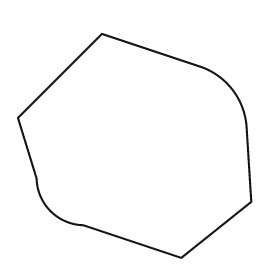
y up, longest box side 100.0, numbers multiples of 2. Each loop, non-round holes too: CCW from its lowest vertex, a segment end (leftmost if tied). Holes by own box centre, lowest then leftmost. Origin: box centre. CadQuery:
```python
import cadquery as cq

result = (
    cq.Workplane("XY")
    .moveTo(20.0, -48.0)
    .lineTo(50.0, -24.0)
    .lineTo(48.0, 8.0)
    .threePointArc((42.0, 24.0), (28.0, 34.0))
    .lineTo(-14.0, 48.0)
    .lineTo(-50.0, 12.0)
    .lineTo(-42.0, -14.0)
    .threePointArc((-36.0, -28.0), (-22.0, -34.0))
    .close()
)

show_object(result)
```